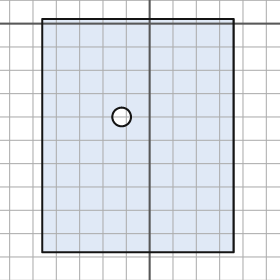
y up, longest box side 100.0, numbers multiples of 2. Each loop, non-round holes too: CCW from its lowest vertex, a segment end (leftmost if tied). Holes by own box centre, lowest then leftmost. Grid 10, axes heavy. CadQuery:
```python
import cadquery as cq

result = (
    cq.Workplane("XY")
    .moveTo(-46.0, -98.0)
    .lineTo(36.0, -98.0)
    .lineTo(36.0, 2.0)
    .lineTo(-46.0, 2.0)
    .close()
    .moveTo(-12.0, -40.0)
    .circle(4.0)
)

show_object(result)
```